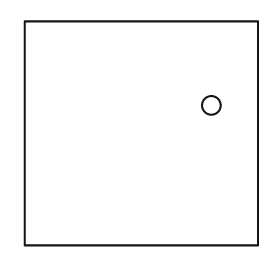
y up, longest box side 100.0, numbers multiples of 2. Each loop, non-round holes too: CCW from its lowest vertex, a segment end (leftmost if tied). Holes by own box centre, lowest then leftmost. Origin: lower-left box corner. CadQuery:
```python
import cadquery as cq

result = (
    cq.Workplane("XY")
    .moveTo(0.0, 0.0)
    .lineTo(100.0, 0.0)
    .lineTo(100.0, 96.0)
    .lineTo(0.0, 96.0)
    .close()
    .moveTo(80.0, 60.0)
    .circle(4.0)
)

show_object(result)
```